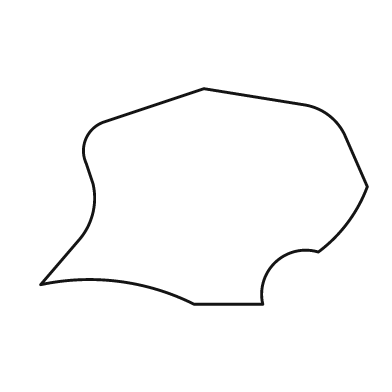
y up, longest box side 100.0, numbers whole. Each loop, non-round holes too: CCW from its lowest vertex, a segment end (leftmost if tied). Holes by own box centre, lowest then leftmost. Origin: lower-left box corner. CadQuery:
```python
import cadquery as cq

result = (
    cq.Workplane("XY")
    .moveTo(47.0, 0.0)
    .lineTo(68.0, 0.0)
    .threePointArc((72.0, 13.0), (85.0, 16.0))
    .threePointArc((94.0, 25.0), (100.0, 36.0))
    .lineTo(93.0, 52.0)
    .threePointArc((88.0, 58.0), (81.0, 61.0))
    .lineTo(50.0, 66.0)
    .lineTo(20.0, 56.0)
    .threePointArc((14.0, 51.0), (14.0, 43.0))
    .lineTo(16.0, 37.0)
    .threePointArc((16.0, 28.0), (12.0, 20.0))
    .lineTo(0.0, 6.0)
    .threePointArc((24.0, 7.0), (47.0, 0.0))
    .close()
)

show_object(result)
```